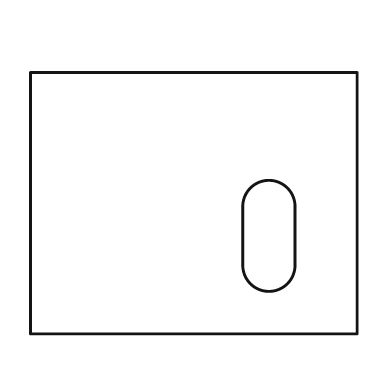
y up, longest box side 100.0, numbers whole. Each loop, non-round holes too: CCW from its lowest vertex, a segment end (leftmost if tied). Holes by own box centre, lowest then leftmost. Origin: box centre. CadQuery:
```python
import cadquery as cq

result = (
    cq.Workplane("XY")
    .moveTo(-50.0, -40.0)
    .lineTo(50.0, -40.0)
    .lineTo(50.0, 40.0)
    .lineTo(-50.0, 40.0)
    .close()
    .moveTo(15.0, -19.0)
    .threePointArc((23.0, -27.0), (31.0, -19.0))
    .lineTo(31.0, -1.0)
    .threePointArc((23.0, 7.0), (15.0, -1.0))
    .close()
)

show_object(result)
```